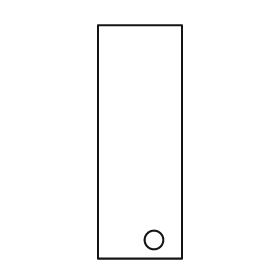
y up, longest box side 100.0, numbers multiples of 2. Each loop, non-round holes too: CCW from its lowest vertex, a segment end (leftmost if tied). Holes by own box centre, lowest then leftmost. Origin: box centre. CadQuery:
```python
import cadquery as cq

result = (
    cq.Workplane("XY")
    .moveTo(-18.0, -50.0)
    .lineTo(18.0, -50.0)
    .lineTo(18.0, 50.0)
    .lineTo(-18.0, 50.0)
    .close()
    .moveTo(6.0, -42.0)
    .circle(4.0)
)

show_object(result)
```